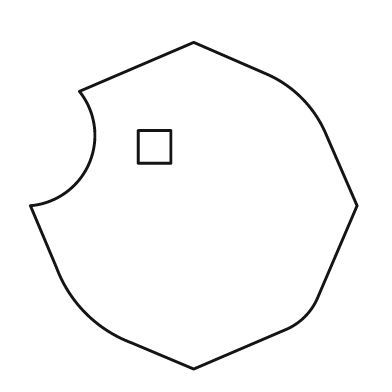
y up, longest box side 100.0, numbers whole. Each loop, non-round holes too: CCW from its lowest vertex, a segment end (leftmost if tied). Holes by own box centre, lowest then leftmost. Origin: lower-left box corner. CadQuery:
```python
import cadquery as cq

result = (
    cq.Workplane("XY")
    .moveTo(50.0, 0.0)
    .lineTo(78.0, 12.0)
    .threePointArc((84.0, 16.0), (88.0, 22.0))
    .lineTo(100.0, 50.0)
    .lineTo(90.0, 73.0)
    .threePointArc((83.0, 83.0), (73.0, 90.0))
    .lineTo(50.0, 100.0)
    .lineTo(15.0, 85.0)
    .threePointArc((18.0, 63.0), (0.0, 50.0))
    .lineTo(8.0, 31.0)
    .threePointArc((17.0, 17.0), (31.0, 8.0))
    .close()
    .moveTo(33.0, 63.0)
    .lineTo(43.0, 63.0)
    .lineTo(43.0, 73.0)
    .lineTo(33.0, 73.0)
    .close()
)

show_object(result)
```